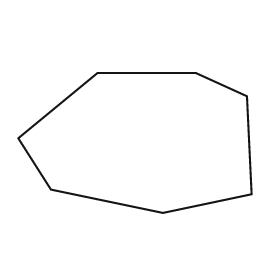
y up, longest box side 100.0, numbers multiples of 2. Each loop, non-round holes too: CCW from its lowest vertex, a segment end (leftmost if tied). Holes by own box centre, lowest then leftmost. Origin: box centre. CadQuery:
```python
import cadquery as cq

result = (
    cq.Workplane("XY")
    .moveTo(12.0, -30.0)
    .lineTo(50.0, -22.0)
    .lineTo(48.0, 20.0)
    .lineTo(26.0, 30.0)
    .lineTo(-16.0, 30.0)
    .lineTo(-50.0, 2.0)
    .lineTo(-36.0, -20.0)
    .close()
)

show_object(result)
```